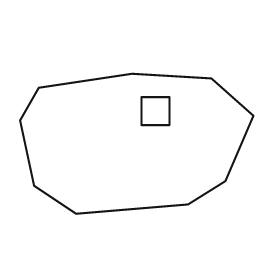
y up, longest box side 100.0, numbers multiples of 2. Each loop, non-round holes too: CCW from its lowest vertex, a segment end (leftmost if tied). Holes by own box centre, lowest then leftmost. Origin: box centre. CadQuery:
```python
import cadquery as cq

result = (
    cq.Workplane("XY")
    .moveTo(-26.0, -30.0)
    .lineTo(22.0, -26.0)
    .lineTo(38.0, -16.0)
    .lineTo(50.0, 12.0)
    .lineTo(32.0, 28.0)
    .lineTo(-2.0, 30.0)
    .lineTo(-42.0, 24.0)
    .lineTo(-50.0, 10.0)
    .lineTo(-44.0, -18.0)
    .close()
    .moveTo(2.0, 8.0)
    .lineTo(14.0, 8.0)
    .lineTo(14.0, 20.0)
    .lineTo(2.0, 20.0)
    .close()
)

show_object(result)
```